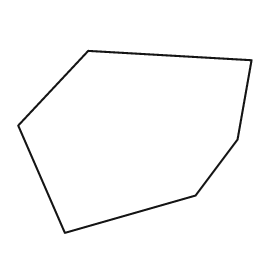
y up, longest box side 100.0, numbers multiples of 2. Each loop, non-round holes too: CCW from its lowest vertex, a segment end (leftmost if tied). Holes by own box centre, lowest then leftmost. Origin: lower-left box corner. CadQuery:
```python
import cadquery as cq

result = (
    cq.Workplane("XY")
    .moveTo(20.0, 0.0)
    .lineTo(76.0, 16.0)
    .lineTo(94.0, 40.0)
    .lineTo(100.0, 74.0)
    .lineTo(30.0, 78.0)
    .lineTo(0.0, 46.0)
    .close()
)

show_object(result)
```